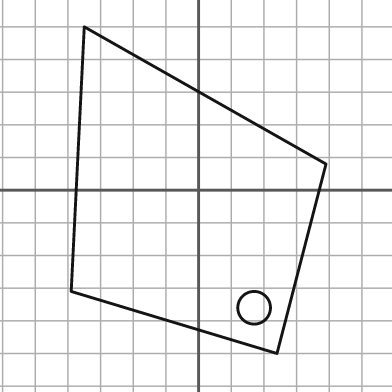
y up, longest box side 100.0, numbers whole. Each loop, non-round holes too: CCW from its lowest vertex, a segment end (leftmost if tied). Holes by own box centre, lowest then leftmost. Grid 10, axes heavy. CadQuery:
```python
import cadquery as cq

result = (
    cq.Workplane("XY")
    .moveTo(24.0, -50.0)
    .lineTo(39.0, 8.0)
    .lineTo(-35.0, 50.0)
    .lineTo(-39.0, -31.0)
    .close()
    .moveTo(17.0, -36.0)
    .circle(5.0)
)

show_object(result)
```